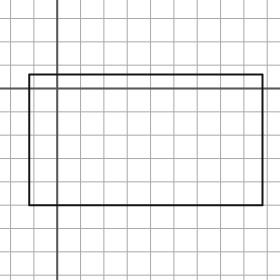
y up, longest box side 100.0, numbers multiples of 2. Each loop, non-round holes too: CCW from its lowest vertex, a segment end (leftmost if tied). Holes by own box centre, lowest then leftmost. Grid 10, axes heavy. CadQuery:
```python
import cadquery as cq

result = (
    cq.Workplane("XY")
    .moveTo(-12.0, -50.0)
    .lineTo(88.0, -50.0)
    .lineTo(88.0, 6.0)
    .lineTo(-12.0, 6.0)
    .close()
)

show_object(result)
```